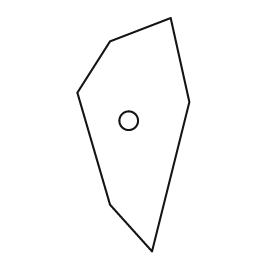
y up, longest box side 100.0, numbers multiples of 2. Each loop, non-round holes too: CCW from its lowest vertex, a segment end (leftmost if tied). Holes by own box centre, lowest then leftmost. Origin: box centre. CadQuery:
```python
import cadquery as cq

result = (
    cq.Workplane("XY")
    .moveTo(8.0, -50.0)
    .lineTo(24.0, 14.0)
    .lineTo(16.0, 50.0)
    .lineTo(-10.0, 40.0)
    .lineTo(-24.0, 18.0)
    .lineTo(-10.0, -30.0)
    .close()
    .moveTo(-2.0, 6.0)
    .circle(4.0)
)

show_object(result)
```